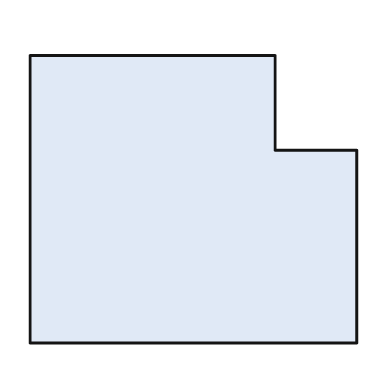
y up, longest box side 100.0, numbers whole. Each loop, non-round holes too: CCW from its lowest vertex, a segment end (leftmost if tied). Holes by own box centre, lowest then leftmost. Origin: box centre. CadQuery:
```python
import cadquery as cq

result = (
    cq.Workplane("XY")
    .moveTo(-50.0, -44.0)
    .lineTo(50.0, -44.0)
    .lineTo(50.0, 15.0)
    .lineTo(25.0, 15.0)
    .lineTo(25.0, 44.0)
    .lineTo(-50.0, 44.0)
    .close()
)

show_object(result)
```